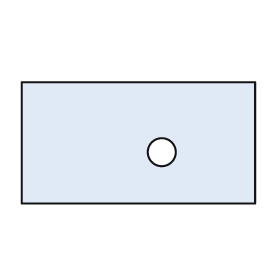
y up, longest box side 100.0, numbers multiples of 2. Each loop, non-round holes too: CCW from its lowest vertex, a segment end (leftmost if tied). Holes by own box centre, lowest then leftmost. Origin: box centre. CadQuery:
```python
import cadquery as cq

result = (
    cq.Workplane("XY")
    .moveTo(-50.0, -26.0)
    .lineTo(50.0, -26.0)
    .lineTo(50.0, 26.0)
    .lineTo(-50.0, 26.0)
    .close()
    .moveTo(10.0, -4.0)
    .circle(6.0)
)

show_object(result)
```